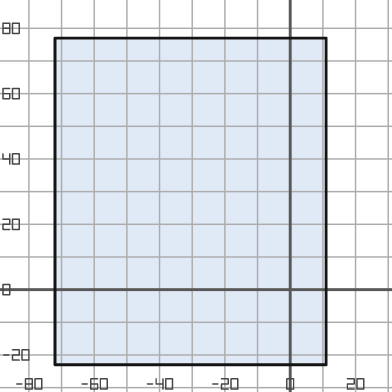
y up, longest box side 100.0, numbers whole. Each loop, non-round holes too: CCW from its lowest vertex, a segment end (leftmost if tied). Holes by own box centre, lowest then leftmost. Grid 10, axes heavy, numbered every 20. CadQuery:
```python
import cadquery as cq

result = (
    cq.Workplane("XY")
    .moveTo(-72.0, -23.0)
    .lineTo(11.0, -23.0)
    .lineTo(11.0, 77.0)
    .lineTo(-72.0, 77.0)
    .close()
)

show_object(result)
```